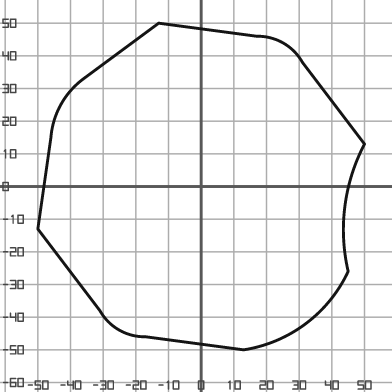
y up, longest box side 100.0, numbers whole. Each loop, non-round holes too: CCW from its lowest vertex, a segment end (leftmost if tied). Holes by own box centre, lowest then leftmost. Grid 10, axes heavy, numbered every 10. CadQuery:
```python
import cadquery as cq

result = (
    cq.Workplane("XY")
    .moveTo(13.0, -50.0)
    .threePointArc((32.0, -42.0), (45.0, -26.0))
    .threePointArc((44.0, -6.0), (50.0, 13.0))
    .lineTo(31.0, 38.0)
    .threePointArc((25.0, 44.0), (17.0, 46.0))
    .lineTo(-13.0, 50.0)
    .lineTo(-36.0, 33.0)
    .threePointArc((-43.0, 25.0), (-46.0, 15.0))
    .lineTo(-50.0, -13.0)
    .lineTo(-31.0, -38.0)
    .threePointArc((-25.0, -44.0), (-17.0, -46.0))
    .close()
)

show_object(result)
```